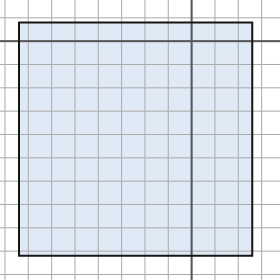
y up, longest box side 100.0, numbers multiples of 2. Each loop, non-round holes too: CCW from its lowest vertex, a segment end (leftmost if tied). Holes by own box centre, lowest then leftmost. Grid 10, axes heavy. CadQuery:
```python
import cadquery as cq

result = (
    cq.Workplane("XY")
    .moveTo(-74.0, -92.0)
    .lineTo(26.0, -92.0)
    .lineTo(26.0, 8.0)
    .lineTo(-74.0, 8.0)
    .close()
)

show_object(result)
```